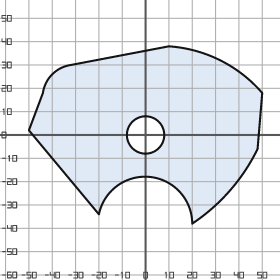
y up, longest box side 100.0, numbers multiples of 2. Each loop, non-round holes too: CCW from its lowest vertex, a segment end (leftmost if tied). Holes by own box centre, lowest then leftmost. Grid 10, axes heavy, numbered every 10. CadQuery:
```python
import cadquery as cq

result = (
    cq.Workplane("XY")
    .moveTo(20.0, -38.0)
    .threePointArc((36.0, -24.0), (48.0, -6.0))
    .lineTo(50.0, 18.0)
    .threePointArc((32.0, 32.0), (10.0, 38.0))
    .lineTo(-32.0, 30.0)
    .threePointArc((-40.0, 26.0), (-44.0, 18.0))
    .lineTo(-50.0, 2.0)
    .lineTo(-20.0, -34.0)
    .threePointArc((2.0, -18.0), (20.0, -38.0))
    .close()
    .moveTo(0.0, 0.0)
    .circle(8.0)
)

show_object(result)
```